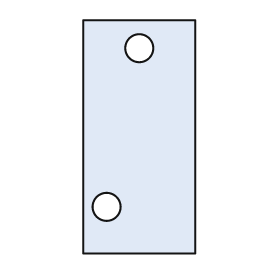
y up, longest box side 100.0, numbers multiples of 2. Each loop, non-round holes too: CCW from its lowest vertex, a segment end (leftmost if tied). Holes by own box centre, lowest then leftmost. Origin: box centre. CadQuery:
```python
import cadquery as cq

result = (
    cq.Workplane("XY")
    .moveTo(-24.0, -50.0)
    .lineTo(24.0, -50.0)
    .lineTo(24.0, 50.0)
    .lineTo(-24.0, 50.0)
    .close()
    .moveTo(-14.0, -30.0)
    .circle(6.0)
    .moveTo(0.0, 38.0)
    .circle(6.0)
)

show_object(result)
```